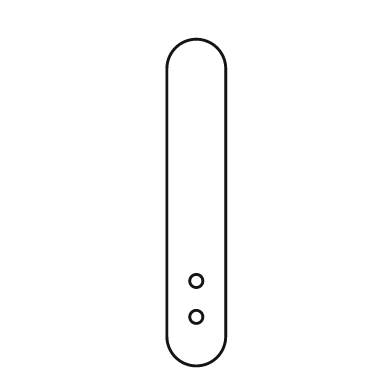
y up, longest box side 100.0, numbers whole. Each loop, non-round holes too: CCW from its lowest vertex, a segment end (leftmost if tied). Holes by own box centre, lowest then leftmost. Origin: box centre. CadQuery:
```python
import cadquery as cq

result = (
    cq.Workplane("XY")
    .moveTo(-9.0, -41.0)
    .threePointArc((0.0, -50.0), (9.0, -41.0))
    .lineTo(9.0, 41.0)
    .threePointArc((0.0, 50.0), (-9.0, 41.0))
    .close()
    .moveTo(0.0, -35.0)
    .circle(2.0)
    .moveTo(0.0, -24.0)
    .circle(2.0)
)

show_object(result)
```